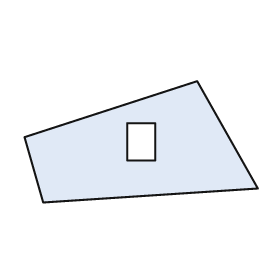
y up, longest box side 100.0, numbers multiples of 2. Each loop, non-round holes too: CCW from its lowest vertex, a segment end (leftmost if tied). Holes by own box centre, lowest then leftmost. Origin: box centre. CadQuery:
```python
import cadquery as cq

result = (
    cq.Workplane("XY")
    .moveTo(-42.0, -26.0)
    .lineTo(50.0, -20.0)
    .lineTo(24.0, 26.0)
    .lineTo(-50.0, 2.0)
    .close()
    .moveTo(-6.0, -8.0)
    .lineTo(6.0, -8.0)
    .lineTo(6.0, 8.0)
    .lineTo(-6.0, 8.0)
    .close()
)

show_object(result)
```